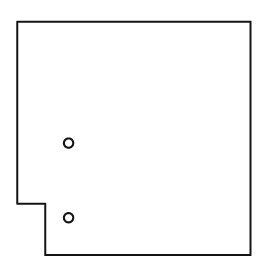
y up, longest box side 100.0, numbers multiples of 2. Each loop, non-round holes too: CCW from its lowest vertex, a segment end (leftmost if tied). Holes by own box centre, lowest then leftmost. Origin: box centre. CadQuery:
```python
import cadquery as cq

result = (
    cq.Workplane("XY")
    .moveTo(-38.0, -50.0)
    .lineTo(50.0, -50.0)
    .lineTo(50.0, 50.0)
    .lineTo(-50.0, 50.0)
    .lineTo(-50.0, -28.0)
    .lineTo(-38.0, -28.0)
    .close()
    .moveTo(-28.0, -34.0)
    .circle(2.0)
    .moveTo(-28.0, -2.0)
    .circle(2.0)
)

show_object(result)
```